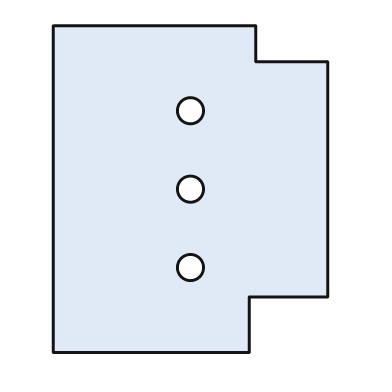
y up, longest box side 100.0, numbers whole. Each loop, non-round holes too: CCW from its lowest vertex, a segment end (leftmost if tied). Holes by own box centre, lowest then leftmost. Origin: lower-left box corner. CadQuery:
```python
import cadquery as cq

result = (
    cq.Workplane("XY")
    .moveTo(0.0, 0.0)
    .lineTo(60.0, 0.0)
    .lineTo(60.0, 17.0)
    .lineTo(84.0, 17.0)
    .lineTo(84.0, 89.0)
    .lineTo(62.0, 89.0)
    .lineTo(62.0, 100.0)
    .lineTo(0.0, 100.0)
    .close()
    .moveTo(42.0, 26.0)
    .circle(4.0)
    .moveTo(42.0, 50.0)
    .circle(4.0)
    .moveTo(42.0, 74.0)
    .circle(4.0)
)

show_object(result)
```